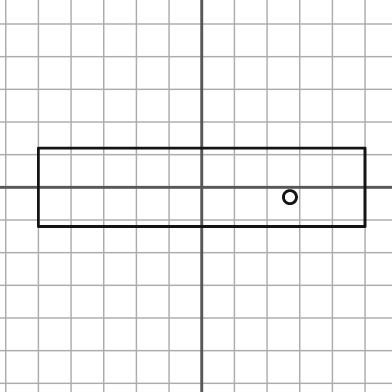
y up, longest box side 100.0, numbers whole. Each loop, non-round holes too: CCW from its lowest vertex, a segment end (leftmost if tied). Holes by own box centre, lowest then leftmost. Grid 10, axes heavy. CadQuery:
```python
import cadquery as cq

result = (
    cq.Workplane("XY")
    .moveTo(-50.0, -12.0)
    .lineTo(50.0, -12.0)
    .lineTo(50.0, 12.0)
    .lineTo(-50.0, 12.0)
    .close()
    .moveTo(27.0, -3.0)
    .circle(2.0)
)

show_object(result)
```